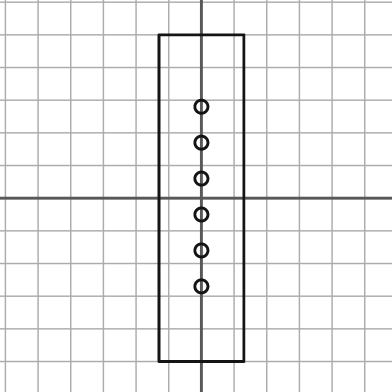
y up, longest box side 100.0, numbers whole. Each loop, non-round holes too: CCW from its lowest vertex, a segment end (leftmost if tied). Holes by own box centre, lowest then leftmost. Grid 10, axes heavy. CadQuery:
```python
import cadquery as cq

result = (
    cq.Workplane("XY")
    .moveTo(-13.0, -50.0)
    .lineTo(13.0, -50.0)
    .lineTo(13.0, 50.0)
    .lineTo(-13.0, 50.0)
    .close()
    .moveTo(0.0, -27.0)
    .circle(2.0)
    .moveTo(0.0, -16.0)
    .circle(2.0)
    .moveTo(0.0, -5.0)
    .circle(2.0)
    .moveTo(0.0, 6.0)
    .circle(2.0)
    .moveTo(0.0, 17.0)
    .circle(2.0)
    .moveTo(0.0, 28.0)
    .circle(2.0)
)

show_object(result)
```